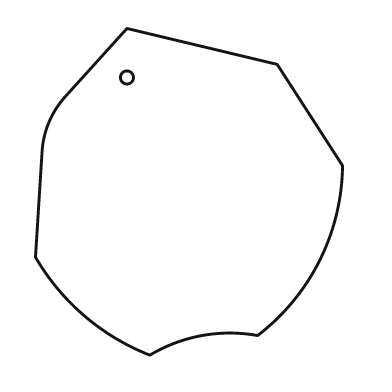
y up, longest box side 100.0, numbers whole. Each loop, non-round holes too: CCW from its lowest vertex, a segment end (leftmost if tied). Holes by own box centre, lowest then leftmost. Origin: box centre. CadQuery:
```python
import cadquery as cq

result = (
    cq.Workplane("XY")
    .moveTo(-12.0, -50.0)
    .threePointArc((4.0, -44.0), (21.0, -44.0))
    .threePointArc((40.0, -21.0), (47.0, 8.0))
    .lineTo(27.0, 39.0)
    .lineTo(-19.0, 50.0)
    .lineTo(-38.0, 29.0)
    .threePointArc((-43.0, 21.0), (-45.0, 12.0))
    .lineTo(-47.0, -20.0)
    .threePointArc((-32.0, -38.0), (-12.0, -50.0))
    .close()
    .moveTo(-19.0, 35.0)
    .circle(2.0)
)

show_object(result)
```